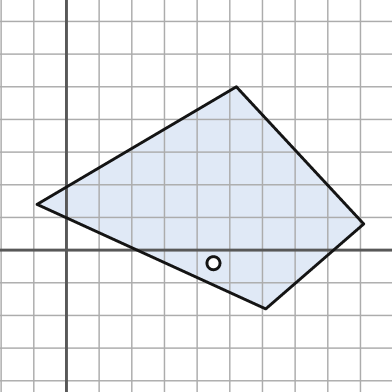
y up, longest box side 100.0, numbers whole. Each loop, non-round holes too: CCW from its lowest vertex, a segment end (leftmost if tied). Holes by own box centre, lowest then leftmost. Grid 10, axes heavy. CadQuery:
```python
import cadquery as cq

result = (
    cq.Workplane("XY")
    .moveTo(61.0, -18.0)
    .lineTo(91.0, 8.0)
    .lineTo(52.0, 50.0)
    .lineTo(-9.0, 14.0)
    .close()
    .moveTo(45.0, -4.0)
    .circle(2.0)
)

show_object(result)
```